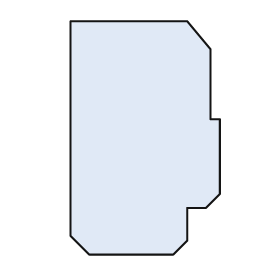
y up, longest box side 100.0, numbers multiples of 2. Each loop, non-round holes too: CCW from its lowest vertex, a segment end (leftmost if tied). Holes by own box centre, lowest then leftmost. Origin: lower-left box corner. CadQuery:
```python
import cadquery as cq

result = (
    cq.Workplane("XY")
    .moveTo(8.0, 0.0)
    .lineTo(44.0, 0.0)
    .lineTo(50.0, 6.0)
    .lineTo(50.0, 20.0)
    .lineTo(58.0, 20.0)
    .lineTo(64.0, 26.0)
    .lineTo(64.0, 58.0)
    .lineTo(60.0, 58.0)
    .lineTo(60.0, 88.0)
    .lineTo(50.0, 100.0)
    .lineTo(0.0, 100.0)
    .lineTo(0.0, 8.0)
    .close()
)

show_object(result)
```